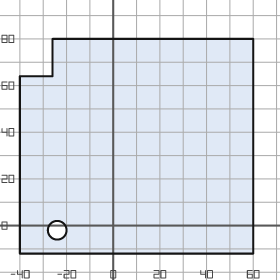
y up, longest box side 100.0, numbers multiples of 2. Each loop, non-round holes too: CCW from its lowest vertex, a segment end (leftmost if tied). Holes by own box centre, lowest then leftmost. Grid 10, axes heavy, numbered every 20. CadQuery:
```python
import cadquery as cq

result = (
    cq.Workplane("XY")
    .moveTo(-40.0, -12.0)
    .lineTo(60.0, -12.0)
    .lineTo(60.0, 80.0)
    .lineTo(-26.0, 80.0)
    .lineTo(-26.0, 64.0)
    .lineTo(-40.0, 64.0)
    .close()
    .moveTo(-24.0, -2.0)
    .circle(4.0)
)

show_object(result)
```